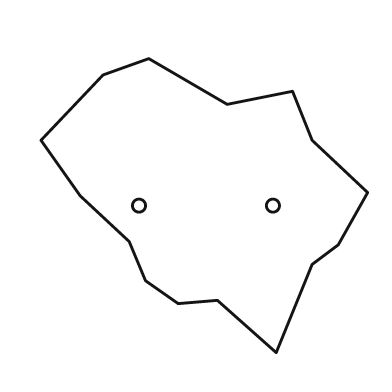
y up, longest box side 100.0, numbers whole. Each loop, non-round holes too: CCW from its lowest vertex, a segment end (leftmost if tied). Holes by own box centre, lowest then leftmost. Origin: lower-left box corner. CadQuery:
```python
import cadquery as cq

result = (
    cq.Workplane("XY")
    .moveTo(72.0, 0.0)
    .lineTo(83.0, 27.0)
    .lineTo(91.0, 33.0)
    .lineTo(100.0, 49.0)
    .lineTo(83.0, 65.0)
    .lineTo(77.0, 80.0)
    .lineTo(57.0, 76.0)
    .lineTo(33.0, 90.0)
    .lineTo(19.0, 85.0)
    .lineTo(0.0, 65.0)
    .lineTo(12.0, 48.0)
    .lineTo(27.0, 34.0)
    .lineTo(32.0, 22.0)
    .lineTo(42.0, 15.0)
    .lineTo(54.0, 16.0)
    .close()
    .moveTo(30.0, 45.0)
    .circle(2.0)
    .moveTo(71.0, 45.0)
    .circle(2.0)
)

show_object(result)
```